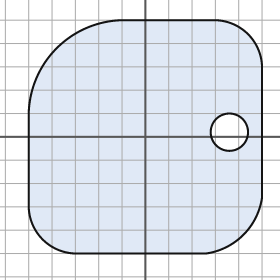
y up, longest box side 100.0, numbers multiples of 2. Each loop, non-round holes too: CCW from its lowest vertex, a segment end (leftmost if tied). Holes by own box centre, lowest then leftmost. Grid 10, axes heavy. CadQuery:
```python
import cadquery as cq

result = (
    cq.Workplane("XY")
    .moveTo(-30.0, -50.0)
    .lineTo(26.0, -50.0)
    .threePointArc((42.0, -42.0), (50.0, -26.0))
    .lineTo(50.0, 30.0)
    .threePointArc((44.0, 44.0), (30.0, 50.0))
    .lineTo(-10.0, 50.0)
    .threePointArc((-38.0, 38.0), (-50.0, 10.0))
    .lineTo(-50.0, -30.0)
    .threePointArc((-44.0, -44.0), (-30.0, -50.0))
    .close()
    .moveTo(36.0, 2.0)
    .circle(8.0)
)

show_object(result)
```